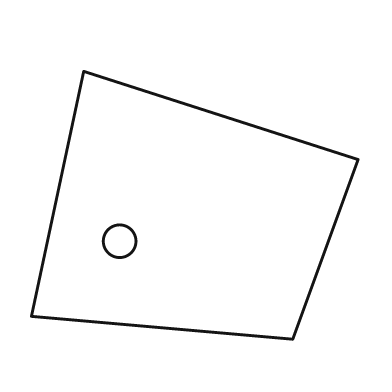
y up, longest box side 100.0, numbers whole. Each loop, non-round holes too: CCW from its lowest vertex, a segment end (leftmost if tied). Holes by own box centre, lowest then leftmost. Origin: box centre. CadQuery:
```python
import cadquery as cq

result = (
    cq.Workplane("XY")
    .moveTo(30.0, -41.0)
    .lineTo(50.0, 14.0)
    .lineTo(-34.0, 41.0)
    .lineTo(-50.0, -34.0)
    .close()
    .moveTo(-23.0, -11.0)
    .circle(5.0)
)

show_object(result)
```